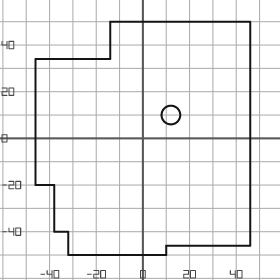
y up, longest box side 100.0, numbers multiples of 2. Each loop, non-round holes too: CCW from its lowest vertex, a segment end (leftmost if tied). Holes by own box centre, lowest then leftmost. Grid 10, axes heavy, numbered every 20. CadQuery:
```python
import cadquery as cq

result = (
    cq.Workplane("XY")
    .moveTo(-32.0, -50.0)
    .lineTo(10.0, -50.0)
    .lineTo(10.0, -46.0)
    .lineTo(46.0, -46.0)
    .lineTo(46.0, 50.0)
    .lineTo(-14.0, 50.0)
    .lineTo(-14.0, 34.0)
    .lineTo(-46.0, 34.0)
    .lineTo(-46.0, -20.0)
    .lineTo(-38.0, -20.0)
    .lineTo(-38.0, -40.0)
    .lineTo(-32.0, -40.0)
    .close()
    .moveTo(12.0, 10.0)
    .circle(4.0)
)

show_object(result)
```